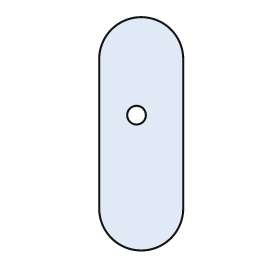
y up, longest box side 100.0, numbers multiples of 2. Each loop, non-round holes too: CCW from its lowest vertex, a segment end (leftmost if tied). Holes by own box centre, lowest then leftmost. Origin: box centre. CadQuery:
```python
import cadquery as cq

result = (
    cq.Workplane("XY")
    .moveTo(-18.0, -32.0)
    .threePointArc((0.0, -50.0), (18.0, -32.0))
    .lineTo(18.0, 32.0)
    .threePointArc((0.0, 50.0), (-18.0, 32.0))
    .close()
    .moveTo(-2.0, 8.0)
    .circle(4.0)
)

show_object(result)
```